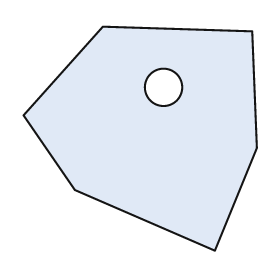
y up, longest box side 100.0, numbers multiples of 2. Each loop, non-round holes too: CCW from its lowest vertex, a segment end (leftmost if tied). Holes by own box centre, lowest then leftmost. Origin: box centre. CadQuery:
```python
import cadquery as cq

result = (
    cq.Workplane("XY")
    .moveTo(32.0, -48.0)
    .lineTo(50.0, -4.0)
    .lineTo(48.0, 46.0)
    .lineTo(-16.0, 48.0)
    .lineTo(-50.0, 10.0)
    .lineTo(-28.0, -22.0)
    .close()
    .moveTo(10.0, 22.0)
    .circle(8.0)
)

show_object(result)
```